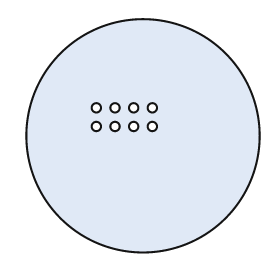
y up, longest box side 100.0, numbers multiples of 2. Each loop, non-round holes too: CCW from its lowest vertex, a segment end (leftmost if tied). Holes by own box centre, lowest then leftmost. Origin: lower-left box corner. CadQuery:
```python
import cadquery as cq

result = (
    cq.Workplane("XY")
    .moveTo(50.0, 50.0)
    .circle(50.0)
    .moveTo(30.0, 54.0)
    .circle(2.0)
    .moveTo(38.0, 54.0)
    .circle(2.0)
    .moveTo(46.0, 54.0)
    .circle(2.0)
    .moveTo(54.0, 54.0)
    .circle(2.0)
    .moveTo(30.0, 62.0)
    .circle(2.0)
    .moveTo(38.0, 62.0)
    .circle(2.0)
    .moveTo(46.0, 62.0)
    .circle(2.0)
    .moveTo(54.0, 62.0)
    .circle(2.0)
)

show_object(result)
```